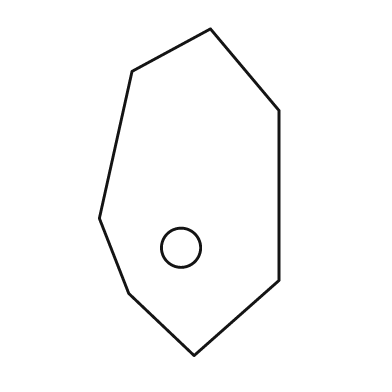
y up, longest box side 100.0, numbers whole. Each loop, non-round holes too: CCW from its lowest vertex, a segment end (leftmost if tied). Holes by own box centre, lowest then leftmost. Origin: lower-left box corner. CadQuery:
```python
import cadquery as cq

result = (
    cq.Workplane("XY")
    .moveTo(29.0, 0.0)
    .lineTo(55.0, 23.0)
    .lineTo(55.0, 75.0)
    .lineTo(34.0, 100.0)
    .lineTo(10.0, 87.0)
    .lineTo(0.0, 42.0)
    .lineTo(9.0, 19.0)
    .close()
    .moveTo(25.0, 33.0)
    .circle(6.0)
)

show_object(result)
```